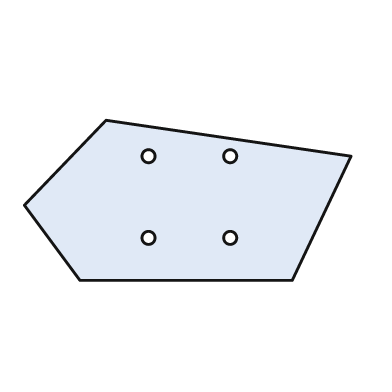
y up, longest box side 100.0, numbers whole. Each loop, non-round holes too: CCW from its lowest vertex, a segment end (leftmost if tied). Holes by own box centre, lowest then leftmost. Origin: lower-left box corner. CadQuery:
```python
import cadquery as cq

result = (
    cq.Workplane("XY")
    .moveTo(17.0, 0.0)
    .lineTo(82.0, 0.0)
    .lineTo(100.0, 38.0)
    .lineTo(25.0, 49.0)
    .lineTo(0.0, 23.0)
    .close()
    .moveTo(38.0, 13.0)
    .circle(2.0)
    .moveTo(63.0, 13.0)
    .circle(2.0)
    .moveTo(38.0, 38.0)
    .circle(2.0)
    .moveTo(63.0, 38.0)
    .circle(2.0)
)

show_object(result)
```